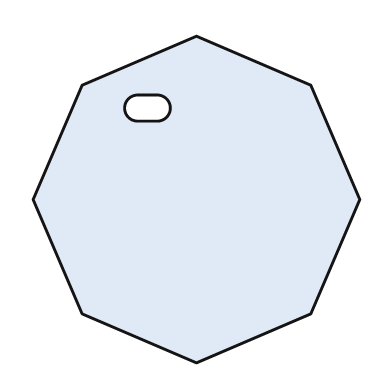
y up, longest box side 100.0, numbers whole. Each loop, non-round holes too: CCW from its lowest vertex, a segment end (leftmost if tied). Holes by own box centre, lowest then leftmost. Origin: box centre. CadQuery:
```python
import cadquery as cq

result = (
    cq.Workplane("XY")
    .moveTo(0.0, -50.0)
    .lineTo(35.0, -35.0)
    .lineTo(50.0, 0.0)
    .lineTo(35.0, 35.0)
    .lineTo(0.0, 50.0)
    .lineTo(-35.0, 35.0)
    .lineTo(-50.0, 0.0)
    .lineTo(-35.0, -35.0)
    .close()
    .moveTo(-18.0, 24.0)
    .lineTo(-12.0, 24.0)
    .threePointArc((-8.0, 28.0), (-12.0, 32.0))
    .lineTo(-18.0, 32.0)
    .threePointArc((-22.0, 28.0), (-18.0, 24.0))
    .close()
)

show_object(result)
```